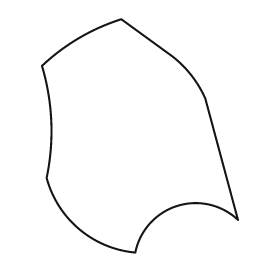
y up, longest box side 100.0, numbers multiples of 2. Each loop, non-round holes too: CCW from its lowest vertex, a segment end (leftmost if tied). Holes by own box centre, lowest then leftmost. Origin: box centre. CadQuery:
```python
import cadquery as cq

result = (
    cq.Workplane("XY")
    .moveTo(-2.0, -50.0)
    .threePointArc((16.0, -30.0), (42.0, -36.0))
    .lineTo(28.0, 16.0)
    .threePointArc((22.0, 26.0), (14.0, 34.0))
    .lineTo(-8.0, 50.0)
    .threePointArc((-26.0, 42.0), (-42.0, 30.0))
    .threePointArc((-38.0, 6.0), (-40.0, -18.0))
    .threePointArc((-26.0, -40.0), (-2.0, -50.0))
    .close()
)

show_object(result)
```